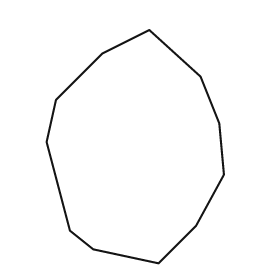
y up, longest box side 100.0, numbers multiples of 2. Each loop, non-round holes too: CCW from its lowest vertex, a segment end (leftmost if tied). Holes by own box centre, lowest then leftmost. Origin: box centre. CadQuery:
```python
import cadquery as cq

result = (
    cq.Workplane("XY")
    .moveTo(10.0, -50.0)
    .lineTo(26.0, -34.0)
    .lineTo(38.0, -12.0)
    .lineTo(36.0, 10.0)
    .lineTo(28.0, 30.0)
    .lineTo(6.0, 50.0)
    .lineTo(-14.0, 40.0)
    .lineTo(-34.0, 20.0)
    .lineTo(-38.0, 2.0)
    .lineTo(-28.0, -36.0)
    .lineTo(-18.0, -44.0)
    .close()
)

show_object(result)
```